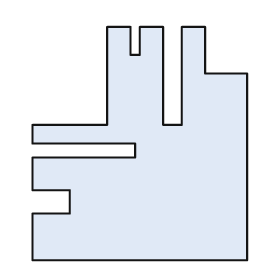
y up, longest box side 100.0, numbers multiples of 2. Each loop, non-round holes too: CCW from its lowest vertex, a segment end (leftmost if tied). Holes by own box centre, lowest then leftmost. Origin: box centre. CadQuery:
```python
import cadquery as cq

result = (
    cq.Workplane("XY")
    .moveTo(-46.0, -50.0)
    .lineTo(46.0, -50.0)
    .lineTo(46.0, 30.0)
    .lineTo(28.0, 30.0)
    .lineTo(28.0, 50.0)
    .lineTo(18.0, 50.0)
    .lineTo(18.0, 8.0)
    .lineTo(10.0, 8.0)
    .lineTo(10.0, 50.0)
    .lineTo(0.0, 50.0)
    .lineTo(0.0, 38.0)
    .lineTo(-4.0, 38.0)
    .lineTo(-4.0, 50.0)
    .lineTo(-14.0, 50.0)
    .lineTo(-14.0, 8.0)
    .lineTo(-46.0, 8.0)
    .lineTo(-46.0, 0.0)
    .lineTo(-2.0, 0.0)
    .lineTo(-2.0, -6.0)
    .lineTo(-46.0, -6.0)
    .lineTo(-46.0, -20.0)
    .lineTo(-30.0, -20.0)
    .lineTo(-30.0, -30.0)
    .lineTo(-46.0, -30.0)
    .close()
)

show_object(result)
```